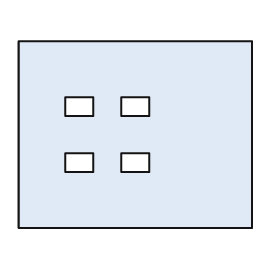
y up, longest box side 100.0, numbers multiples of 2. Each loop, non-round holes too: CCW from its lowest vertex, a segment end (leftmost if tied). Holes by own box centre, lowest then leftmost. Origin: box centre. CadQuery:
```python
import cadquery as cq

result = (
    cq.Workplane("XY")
    .moveTo(-50.0, -40.0)
    .lineTo(50.0, -40.0)
    .lineTo(50.0, 40.0)
    .lineTo(-50.0, 40.0)
    .close()
    .moveTo(-30.0, -16.0)
    .lineTo(-18.0, -16.0)
    .lineTo(-18.0, -8.0)
    .lineTo(-30.0, -8.0)
    .close()
    .moveTo(-6.0, -16.0)
    .lineTo(6.0, -16.0)
    .lineTo(6.0, -8.0)
    .lineTo(-6.0, -8.0)
    .close()
    .moveTo(-30.0, 8.0)
    .lineTo(-18.0, 8.0)
    .lineTo(-18.0, 16.0)
    .lineTo(-30.0, 16.0)
    .close()
    .moveTo(-6.0, 8.0)
    .lineTo(6.0, 8.0)
    .lineTo(6.0, 16.0)
    .lineTo(-6.0, 16.0)
    .close()
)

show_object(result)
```